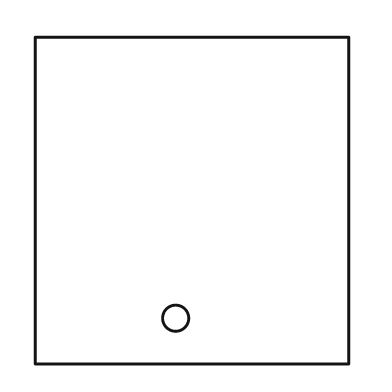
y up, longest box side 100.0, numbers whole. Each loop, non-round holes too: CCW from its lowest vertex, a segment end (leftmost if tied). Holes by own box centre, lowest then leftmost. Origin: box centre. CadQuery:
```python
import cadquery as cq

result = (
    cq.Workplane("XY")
    .moveTo(-48.0, -50.0)
    .lineTo(48.0, -50.0)
    .lineTo(48.0, 50.0)
    .lineTo(-48.0, 50.0)
    .close()
    .moveTo(-5.0, -36.0)
    .circle(4.0)
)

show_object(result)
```